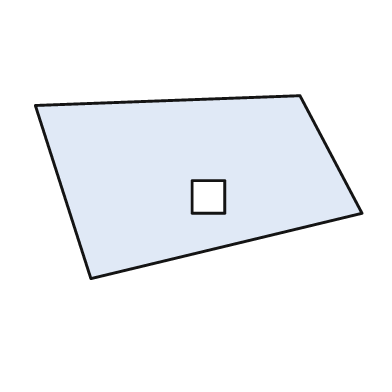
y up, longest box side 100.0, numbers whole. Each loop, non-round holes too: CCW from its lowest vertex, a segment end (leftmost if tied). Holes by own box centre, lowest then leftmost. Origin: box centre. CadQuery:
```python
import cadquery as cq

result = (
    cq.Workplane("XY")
    .moveTo(-33.0, -28.0)
    .lineTo(50.0, -8.0)
    .lineTo(31.0, 28.0)
    .lineTo(-50.0, 25.0)
    .close()
    .moveTo(-2.0, -8.0)
    .lineTo(8.0, -8.0)
    .lineTo(8.0, 2.0)
    .lineTo(-2.0, 2.0)
    .close()
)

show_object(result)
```